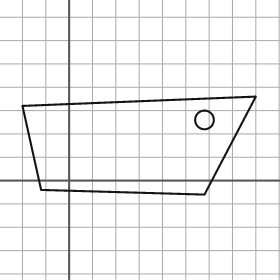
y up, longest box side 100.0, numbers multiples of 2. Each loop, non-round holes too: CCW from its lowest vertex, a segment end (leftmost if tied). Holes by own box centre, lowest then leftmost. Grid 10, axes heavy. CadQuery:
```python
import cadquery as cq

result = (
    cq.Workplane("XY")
    .moveTo(58.0, -6.0)
    .lineTo(80.0, 36.0)
    .lineTo(-20.0, 32.0)
    .lineTo(-12.0, -4.0)
    .close()
    .moveTo(58.0, 26.0)
    .circle(4.0)
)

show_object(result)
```